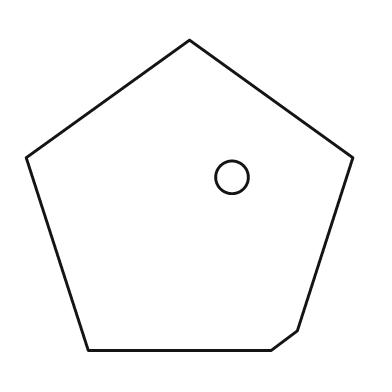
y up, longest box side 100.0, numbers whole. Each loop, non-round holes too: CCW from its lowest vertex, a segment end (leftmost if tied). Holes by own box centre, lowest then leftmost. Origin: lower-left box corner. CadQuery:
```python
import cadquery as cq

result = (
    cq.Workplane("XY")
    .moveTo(19.0, 0.0)
    .lineTo(75.0, 0.0)
    .lineTo(83.0, 6.0)
    .lineTo(100.0, 59.0)
    .lineTo(50.0, 95.0)
    .lineTo(0.0, 59.0)
    .close()
    .moveTo(63.0, 53.0)
    .circle(5.0)
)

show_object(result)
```